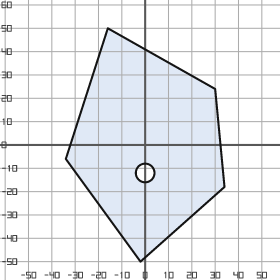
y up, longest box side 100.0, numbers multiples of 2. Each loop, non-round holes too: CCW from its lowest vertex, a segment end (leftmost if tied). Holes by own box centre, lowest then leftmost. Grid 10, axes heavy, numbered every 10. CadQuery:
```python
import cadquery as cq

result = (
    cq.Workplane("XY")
    .moveTo(-2.0, -50.0)
    .lineTo(34.0, -18.0)
    .lineTo(30.0, 24.0)
    .lineTo(-16.0, 50.0)
    .lineTo(-34.0, -6.0)
    .close()
    .moveTo(0.0, -12.0)
    .circle(4.0)
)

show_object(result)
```